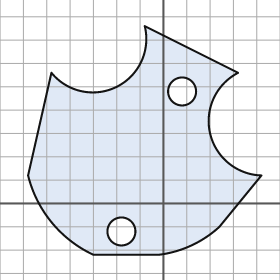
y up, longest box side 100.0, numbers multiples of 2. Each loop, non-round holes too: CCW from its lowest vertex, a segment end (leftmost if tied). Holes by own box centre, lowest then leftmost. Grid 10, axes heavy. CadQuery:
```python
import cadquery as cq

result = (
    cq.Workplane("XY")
    .moveTo(-30.0, -22.0)
    .lineTo(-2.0, -22.0)
    .threePointArc((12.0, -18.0), (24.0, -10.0))
    .lineTo(42.0, 12.0)
    .threePointArc((20.0, 30.0), (32.0, 56.0))
    .lineTo(-8.0, 76.0)
    .threePointArc((-20.0, 50.0), (-48.0, 56.0))
    .lineTo(-58.0, 12.0)
    .threePointArc((-48.0, -8.0), (-30.0, -22.0))
    .close()
    .moveTo(-18.0, -12.0)
    .circle(6.0)
    .moveTo(8.0, 48.0)
    .circle(6.0)
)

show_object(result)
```